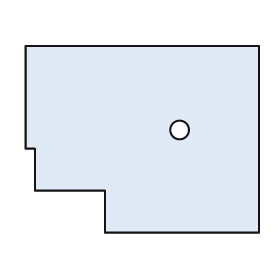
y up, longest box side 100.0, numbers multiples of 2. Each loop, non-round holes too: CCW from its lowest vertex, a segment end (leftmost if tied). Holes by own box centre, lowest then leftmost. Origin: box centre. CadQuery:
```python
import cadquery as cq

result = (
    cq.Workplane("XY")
    .moveTo(-16.0, -40.0)
    .lineTo(50.0, -40.0)
    .lineTo(50.0, 40.0)
    .lineTo(-50.0, 40.0)
    .lineTo(-50.0, -4.0)
    .lineTo(-46.0, -4.0)
    .lineTo(-46.0, -22.0)
    .lineTo(-16.0, -22.0)
    .close()
    .moveTo(16.0, 4.0)
    .circle(4.0)
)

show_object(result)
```